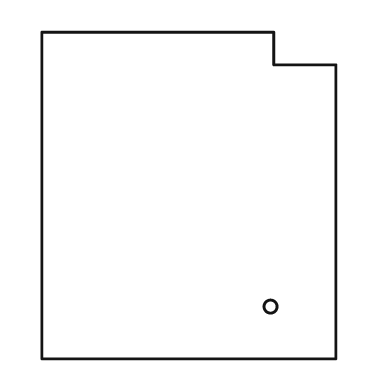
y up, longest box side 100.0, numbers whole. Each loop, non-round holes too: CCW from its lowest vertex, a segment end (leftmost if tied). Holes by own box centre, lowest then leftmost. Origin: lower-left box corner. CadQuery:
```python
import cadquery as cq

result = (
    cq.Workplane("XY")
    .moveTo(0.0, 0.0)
    .lineTo(90.0, 0.0)
    .lineTo(90.0, 90.0)
    .lineTo(71.0, 90.0)
    .lineTo(71.0, 100.0)
    .lineTo(0.0, 100.0)
    .close()
    .moveTo(70.0, 16.0)
    .circle(2.0)
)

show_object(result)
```